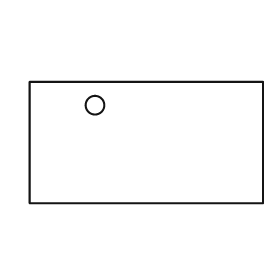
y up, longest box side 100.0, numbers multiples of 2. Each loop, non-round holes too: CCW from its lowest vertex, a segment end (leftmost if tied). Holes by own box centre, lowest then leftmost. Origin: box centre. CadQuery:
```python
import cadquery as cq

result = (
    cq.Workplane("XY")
    .moveTo(-50.0, -26.0)
    .lineTo(50.0, -26.0)
    .lineTo(50.0, 26.0)
    .lineTo(-50.0, 26.0)
    .close()
    .moveTo(-22.0, 16.0)
    .circle(4.0)
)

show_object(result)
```